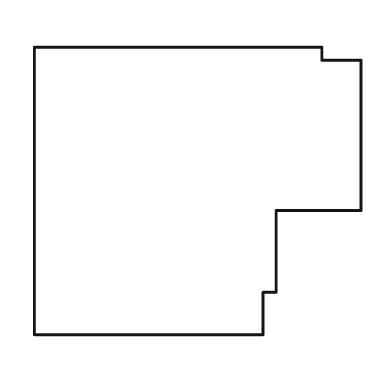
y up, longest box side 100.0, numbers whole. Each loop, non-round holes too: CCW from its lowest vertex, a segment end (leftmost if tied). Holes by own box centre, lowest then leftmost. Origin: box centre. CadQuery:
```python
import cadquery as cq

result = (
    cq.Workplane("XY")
    .moveTo(-50.0, -44.0)
    .lineTo(20.0, -44.0)
    .lineTo(20.0, -31.0)
    .lineTo(24.0, -31.0)
    .lineTo(24.0, -6.0)
    .lineTo(50.0, -6.0)
    .lineTo(50.0, 40.0)
    .lineTo(38.0, 40.0)
    .lineTo(38.0, 44.0)
    .lineTo(-50.0, 44.0)
    .close()
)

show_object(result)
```